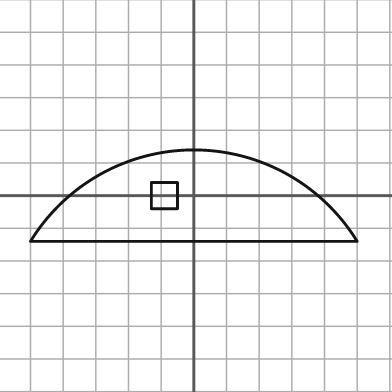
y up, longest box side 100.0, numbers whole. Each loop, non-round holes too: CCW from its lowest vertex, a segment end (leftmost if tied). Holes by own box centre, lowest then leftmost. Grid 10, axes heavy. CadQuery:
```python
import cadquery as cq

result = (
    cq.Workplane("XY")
    .moveTo(-50.0, -14.0)
    .lineTo(50.0, -14.0)
    .threePointArc((0.0, 14.0), (-50.0, -14.0))
    .close()
    .moveTo(-13.0, -4.0)
    .lineTo(-5.0, -4.0)
    .lineTo(-5.0, 4.0)
    .lineTo(-13.0, 4.0)
    .close()
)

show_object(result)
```